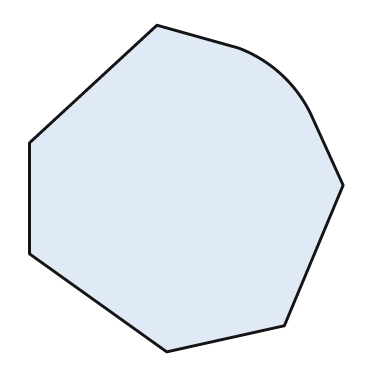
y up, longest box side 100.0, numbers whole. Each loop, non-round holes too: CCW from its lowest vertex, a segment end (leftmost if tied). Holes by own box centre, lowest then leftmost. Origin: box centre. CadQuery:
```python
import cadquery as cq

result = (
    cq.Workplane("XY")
    .moveTo(-6.0, -50.0)
    .lineTo(30.0, -42.0)
    .lineTo(48.0, 1.0)
    .lineTo(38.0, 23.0)
    .threePointArc((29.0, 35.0), (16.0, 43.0))
    .lineTo(-9.0, 50.0)
    .lineTo(-48.0, 14.0)
    .lineTo(-48.0, -20.0)
    .close()
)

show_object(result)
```